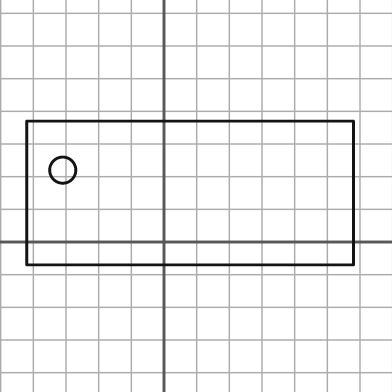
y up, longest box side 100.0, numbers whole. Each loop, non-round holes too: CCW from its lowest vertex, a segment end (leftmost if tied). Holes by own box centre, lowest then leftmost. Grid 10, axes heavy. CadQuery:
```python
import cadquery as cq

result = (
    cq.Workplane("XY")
    .moveTo(-42.0, -7.0)
    .lineTo(58.0, -7.0)
    .lineTo(58.0, 37.0)
    .lineTo(-42.0, 37.0)
    .close()
    .moveTo(-31.0, 22.0)
    .circle(4.0)
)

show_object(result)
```